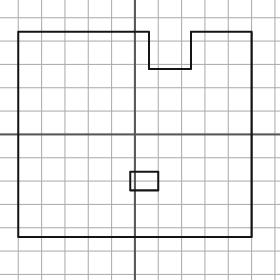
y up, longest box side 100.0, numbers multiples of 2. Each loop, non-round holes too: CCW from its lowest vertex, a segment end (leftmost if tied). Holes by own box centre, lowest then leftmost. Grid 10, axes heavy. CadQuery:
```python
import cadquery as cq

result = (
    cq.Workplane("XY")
    .moveTo(-50.0, -44.0)
    .lineTo(50.0, -44.0)
    .lineTo(50.0, 44.0)
    .lineTo(24.0, 44.0)
    .lineTo(24.0, 28.0)
    .lineTo(6.0, 28.0)
    .lineTo(6.0, 44.0)
    .lineTo(-50.0, 44.0)
    .close()
    .moveTo(-2.0, -24.0)
    .lineTo(10.0, -24.0)
    .lineTo(10.0, -16.0)
    .lineTo(-2.0, -16.0)
    .close()
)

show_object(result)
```